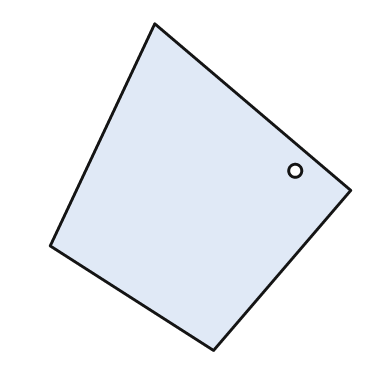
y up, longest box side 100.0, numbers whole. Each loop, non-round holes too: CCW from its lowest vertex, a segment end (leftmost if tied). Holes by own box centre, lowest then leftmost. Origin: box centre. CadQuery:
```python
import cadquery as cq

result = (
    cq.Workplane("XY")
    .moveTo(4.0, -50.0)
    .lineTo(46.0, -1.0)
    .lineTo(-14.0, 50.0)
    .lineTo(-46.0, -18.0)
    .close()
    .moveTo(29.0, 5.0)
    .circle(2.0)
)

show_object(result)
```